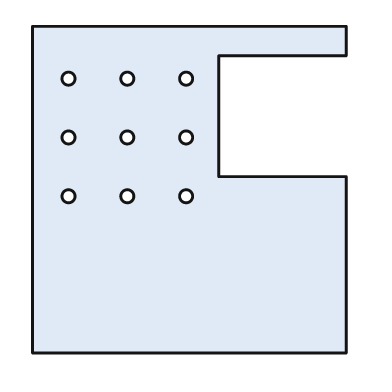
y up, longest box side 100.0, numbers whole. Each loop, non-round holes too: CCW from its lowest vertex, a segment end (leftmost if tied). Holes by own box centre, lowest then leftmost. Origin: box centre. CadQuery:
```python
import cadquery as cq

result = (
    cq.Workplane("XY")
    .moveTo(-48.0, -50.0)
    .lineTo(48.0, -50.0)
    .lineTo(48.0, 4.0)
    .lineTo(9.0, 4.0)
    .lineTo(9.0, 41.0)
    .lineTo(48.0, 41.0)
    .lineTo(48.0, 50.0)
    .lineTo(-48.0, 50.0)
    .close()
    .moveTo(-37.0, -2.0)
    .circle(2.0)
    .moveTo(-19.0, -2.0)
    .circle(2.0)
    .moveTo(-1.0, -2.0)
    .circle(2.0)
    .moveTo(-37.0, 16.0)
    .circle(2.0)
    .moveTo(-19.0, 16.0)
    .circle(2.0)
    .moveTo(-1.0, 16.0)
    .circle(2.0)
    .moveTo(-37.0, 34.0)
    .circle(2.0)
    .moveTo(-19.0, 34.0)
    .circle(2.0)
    .moveTo(-1.0, 34.0)
    .circle(2.0)
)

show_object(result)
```